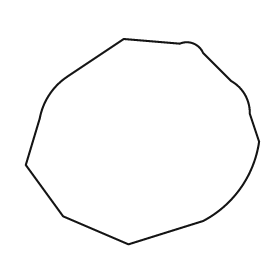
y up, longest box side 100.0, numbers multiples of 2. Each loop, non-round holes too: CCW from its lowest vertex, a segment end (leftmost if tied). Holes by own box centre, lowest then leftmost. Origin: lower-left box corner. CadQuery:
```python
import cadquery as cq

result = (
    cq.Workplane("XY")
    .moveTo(44.0, 0.0)
    .lineTo(76.0, 10.0)
    .threePointArc((92.0, 24.0), (100.0, 44.0))
    .lineTo(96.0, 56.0)
    .threePointArc((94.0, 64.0), (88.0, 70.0))
    .lineTo(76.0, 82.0)
    .threePointArc((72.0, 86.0), (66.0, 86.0))
    .lineTo(42.0, 88.0)
    .lineTo(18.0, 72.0)
    .threePointArc((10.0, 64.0), (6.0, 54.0))
    .lineTo(0.0, 34.0)
    .lineTo(16.0, 12.0)
    .close()
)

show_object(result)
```